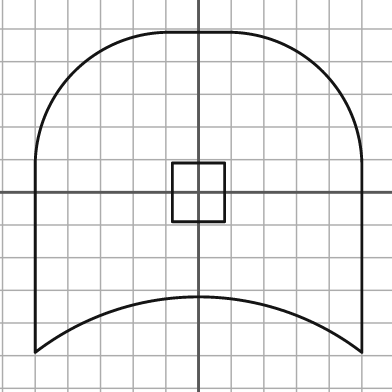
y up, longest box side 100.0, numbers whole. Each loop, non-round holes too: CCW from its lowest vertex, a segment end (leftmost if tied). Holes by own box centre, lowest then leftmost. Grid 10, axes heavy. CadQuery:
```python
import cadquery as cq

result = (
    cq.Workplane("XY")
    .moveTo(-50.0, -49.0)
    .threePointArc((0.0, -32.0), (50.0, -49.0))
    .lineTo(50.0, 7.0)
    .threePointArc((38.0, 37.0), (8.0, 49.0))
    .lineTo(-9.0, 49.0)
    .threePointArc((-38.0, 37.0), (-50.0, 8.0))
    .close()
    .moveTo(-8.0, -9.0)
    .lineTo(8.0, -9.0)
    .lineTo(8.0, 9.0)
    .lineTo(-8.0, 9.0)
    .close()
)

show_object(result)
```